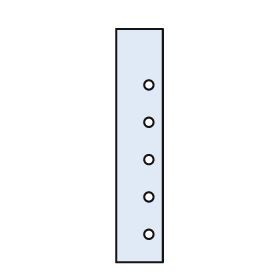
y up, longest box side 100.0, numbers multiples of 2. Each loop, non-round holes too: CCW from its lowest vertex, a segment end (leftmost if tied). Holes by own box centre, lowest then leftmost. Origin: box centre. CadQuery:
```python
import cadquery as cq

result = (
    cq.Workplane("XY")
    .moveTo(-10.0, -50.0)
    .lineTo(10.0, -50.0)
    .lineTo(10.0, 50.0)
    .lineTo(-10.0, 50.0)
    .close()
    .moveTo(4.0, -38.0)
    .circle(2.0)
    .moveTo(4.0, -22.0)
    .circle(2.0)
    .moveTo(4.0, -6.0)
    .circle(2.0)
    .moveTo(4.0, 10.0)
    .circle(2.0)
    .moveTo(4.0, 26.0)
    .circle(2.0)
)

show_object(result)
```